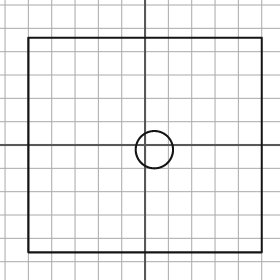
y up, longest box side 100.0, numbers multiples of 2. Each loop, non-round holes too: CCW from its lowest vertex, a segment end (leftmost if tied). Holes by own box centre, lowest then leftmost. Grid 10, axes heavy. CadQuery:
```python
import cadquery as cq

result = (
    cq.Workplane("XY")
    .moveTo(-50.0, -46.0)
    .lineTo(50.0, -46.0)
    .lineTo(50.0, 46.0)
    .lineTo(-50.0, 46.0)
    .close()
    .moveTo(4.0, -2.0)
    .circle(8.0)
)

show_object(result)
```